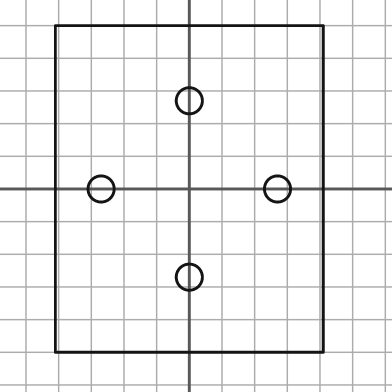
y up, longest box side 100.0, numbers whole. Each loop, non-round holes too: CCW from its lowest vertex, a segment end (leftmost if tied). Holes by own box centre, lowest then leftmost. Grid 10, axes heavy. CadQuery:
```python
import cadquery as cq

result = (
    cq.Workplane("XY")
    .moveTo(-41.0, -50.0)
    .lineTo(41.0, -50.0)
    .lineTo(41.0, 50.0)
    .lineTo(-41.0, 50.0)
    .close()
    .moveTo(0.0, -27.0)
    .circle(4.0)
    .moveTo(-27.0, 0.0)
    .circle(4.0)
    .moveTo(27.0, 0.0)
    .circle(4.0)
    .moveTo(0.0, 27.0)
    .circle(4.0)
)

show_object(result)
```